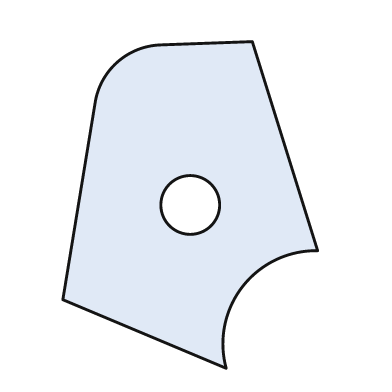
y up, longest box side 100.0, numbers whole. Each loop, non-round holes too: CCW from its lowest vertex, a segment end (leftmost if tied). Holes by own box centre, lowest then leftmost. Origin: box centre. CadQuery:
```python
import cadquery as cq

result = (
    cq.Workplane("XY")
    .moveTo(11.0, -50.0)
    .threePointArc((16.0, -25.0), (39.0, -14.0))
    .lineTo(19.0, 50.0)
    .lineTo(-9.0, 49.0)
    .threePointArc((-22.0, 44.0), (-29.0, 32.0))
    .lineTo(-39.0, -29.0)
    .close()
    .moveTo(0.0, 0.0)
    .circle(9.0)
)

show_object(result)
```